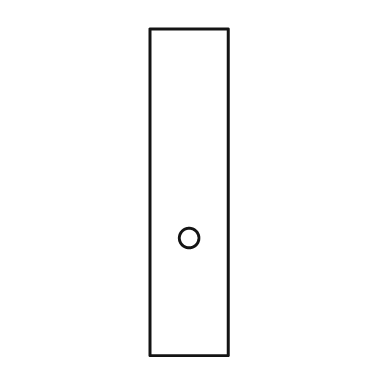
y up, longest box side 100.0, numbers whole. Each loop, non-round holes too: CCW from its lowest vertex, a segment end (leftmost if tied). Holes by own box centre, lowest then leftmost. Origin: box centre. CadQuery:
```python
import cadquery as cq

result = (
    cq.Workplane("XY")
    .moveTo(-12.0, -50.0)
    .lineTo(12.0, -50.0)
    .lineTo(12.0, 50.0)
    .lineTo(-12.0, 50.0)
    .close()
    .moveTo(0.0, -14.0)
    .circle(3.0)
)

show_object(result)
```